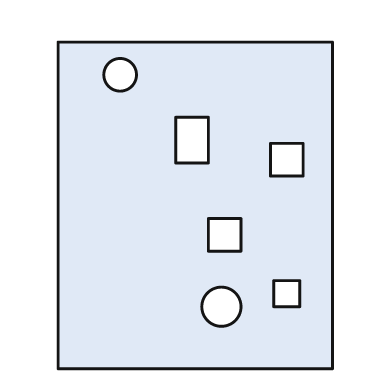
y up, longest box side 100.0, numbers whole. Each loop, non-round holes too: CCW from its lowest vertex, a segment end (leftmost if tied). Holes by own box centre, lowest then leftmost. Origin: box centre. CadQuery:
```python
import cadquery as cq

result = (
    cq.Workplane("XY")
    .moveTo(-42.0, -50.0)
    .lineTo(42.0, -50.0)
    .lineTo(42.0, 50.0)
    .lineTo(-42.0, 50.0)
    .close()
    .moveTo(8.0, -31.0)
    .circle(6.0)
    .moveTo(24.0, -31.0)
    .lineTo(32.0, -31.0)
    .lineTo(32.0, -23.0)
    .lineTo(24.0, -23.0)
    .close()
    .moveTo(4.0, -14.0)
    .lineTo(14.0, -14.0)
    .lineTo(14.0, -4.0)
    .lineTo(4.0, -4.0)
    .close()
    .moveTo(23.0, 9.0)
    .lineTo(33.0, 9.0)
    .lineTo(33.0, 19.0)
    .lineTo(23.0, 19.0)
    .close()
    .moveTo(-6.0, 13.0)
    .lineTo(4.0, 13.0)
    .lineTo(4.0, 27.0)
    .lineTo(-6.0, 27.0)
    .close()
    .moveTo(-23.0, 40.0)
    .circle(5.0)
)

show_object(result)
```